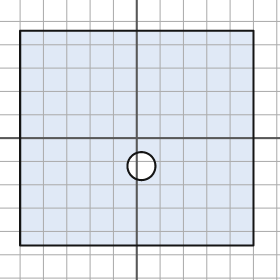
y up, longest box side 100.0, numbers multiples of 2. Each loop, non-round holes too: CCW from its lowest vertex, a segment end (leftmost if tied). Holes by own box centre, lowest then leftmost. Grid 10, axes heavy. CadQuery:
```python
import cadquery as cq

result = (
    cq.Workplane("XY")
    .moveTo(-50.0, -46.0)
    .lineTo(50.0, -46.0)
    .lineTo(50.0, 46.0)
    .lineTo(-50.0, 46.0)
    .close()
    .moveTo(2.0, -12.0)
    .circle(6.0)
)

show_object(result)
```